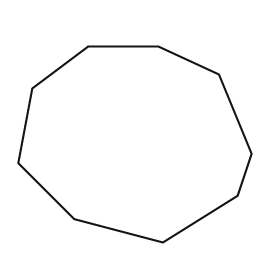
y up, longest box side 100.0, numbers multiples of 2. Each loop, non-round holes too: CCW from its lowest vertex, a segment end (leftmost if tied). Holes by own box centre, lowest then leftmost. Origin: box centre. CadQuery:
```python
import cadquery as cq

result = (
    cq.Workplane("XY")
    .moveTo(12.0, -42.0)
    .lineTo(44.0, -22.0)
    .lineTo(50.0, -4.0)
    .lineTo(36.0, 30.0)
    .lineTo(10.0, 42.0)
    .lineTo(-20.0, 42.0)
    .lineTo(-44.0, 24.0)
    .lineTo(-50.0, -8.0)
    .lineTo(-26.0, -32.0)
    .close()
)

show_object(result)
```